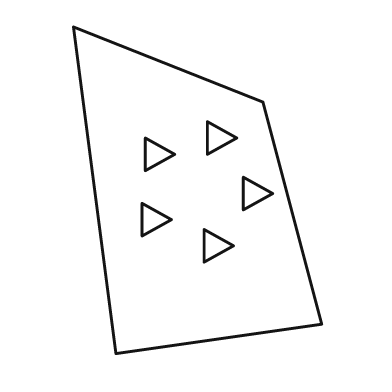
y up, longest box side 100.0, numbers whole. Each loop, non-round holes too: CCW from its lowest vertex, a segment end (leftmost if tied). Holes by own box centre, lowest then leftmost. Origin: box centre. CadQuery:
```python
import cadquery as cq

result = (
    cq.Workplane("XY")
    .moveTo(-25.0, -50.0)
    .lineTo(38.0, -41.0)
    .lineTo(20.0, 27.0)
    .lineTo(-38.0, 50.0)
    .close()
    .moveTo(2.0, -22.0)
    .lineTo(11.0, -17.0)
    .lineTo(2.0, -12.0)
    .close()
    .moveTo(-17.0, -14.0)
    .lineTo(-8.0, -9.0)
    .lineTo(-17.0, -4.0)
    .close()
    .moveTo(14.0, -6.0)
    .lineTo(23.0, -1.0)
    .lineTo(14.0, 4.0)
    .close()
    .moveTo(-16.0, 6.0)
    .lineTo(-7.0, 11.0)
    .lineTo(-16.0, 16.0)
    .close()
    .moveTo(3.0, 11.0)
    .lineTo(12.0, 16.0)
    .lineTo(3.0, 21.0)
    .close()
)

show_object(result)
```